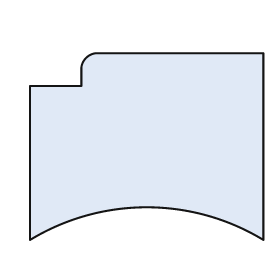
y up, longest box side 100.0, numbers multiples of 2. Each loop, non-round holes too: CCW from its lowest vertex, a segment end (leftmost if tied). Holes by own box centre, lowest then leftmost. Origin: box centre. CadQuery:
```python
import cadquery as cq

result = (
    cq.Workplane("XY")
    .moveTo(-50.0, -40.0)
    .threePointArc((0.0, -26.0), (50.0, -40.0))
    .lineTo(50.0, 40.0)
    .lineTo(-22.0, 40.0)
    .threePointArc((-26.0, 38.0), (-28.0, 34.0))
    .lineTo(-28.0, 26.0)
    .lineTo(-50.0, 26.0)
    .close()
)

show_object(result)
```